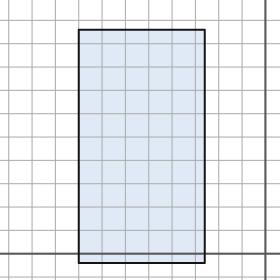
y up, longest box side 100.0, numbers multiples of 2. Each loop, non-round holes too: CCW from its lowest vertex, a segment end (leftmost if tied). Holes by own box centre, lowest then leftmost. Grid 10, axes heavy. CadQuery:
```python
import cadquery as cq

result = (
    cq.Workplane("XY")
    .moveTo(-80.0, -4.0)
    .lineTo(-26.0, -4.0)
    .lineTo(-26.0, 96.0)
    .lineTo(-80.0, 96.0)
    .close()
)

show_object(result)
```